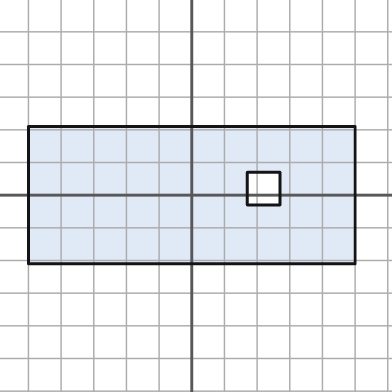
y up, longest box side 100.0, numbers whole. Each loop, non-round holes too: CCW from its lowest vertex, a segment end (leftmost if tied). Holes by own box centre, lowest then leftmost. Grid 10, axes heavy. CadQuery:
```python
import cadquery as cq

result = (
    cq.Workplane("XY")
    .moveTo(-50.0, -21.0)
    .lineTo(50.0, -21.0)
    .lineTo(50.0, 21.0)
    .lineTo(-50.0, 21.0)
    .close()
    .moveTo(17.0, -3.0)
    .lineTo(27.0, -3.0)
    .lineTo(27.0, 7.0)
    .lineTo(17.0, 7.0)
    .close()
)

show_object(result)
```